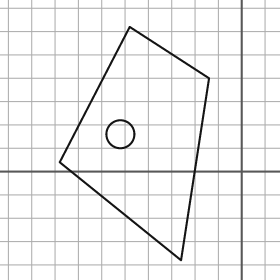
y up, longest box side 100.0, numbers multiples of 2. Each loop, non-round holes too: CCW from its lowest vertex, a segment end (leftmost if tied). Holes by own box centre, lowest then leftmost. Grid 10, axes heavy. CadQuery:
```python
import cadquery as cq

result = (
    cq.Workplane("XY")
    .moveTo(-26.0, -38.0)
    .lineTo(-14.0, 40.0)
    .lineTo(-48.0, 62.0)
    .lineTo(-78.0, 4.0)
    .close()
    .moveTo(-52.0, 16.0)
    .circle(6.0)
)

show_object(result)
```